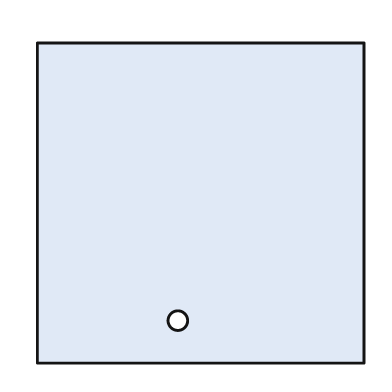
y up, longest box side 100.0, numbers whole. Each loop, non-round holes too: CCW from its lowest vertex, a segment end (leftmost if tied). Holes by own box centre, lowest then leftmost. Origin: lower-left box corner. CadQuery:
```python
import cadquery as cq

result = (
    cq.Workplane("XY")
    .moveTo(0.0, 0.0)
    .lineTo(100.0, 0.0)
    .lineTo(100.0, 98.0)
    .lineTo(0.0, 98.0)
    .close()
    .moveTo(43.0, 13.0)
    .circle(3.0)
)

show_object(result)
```